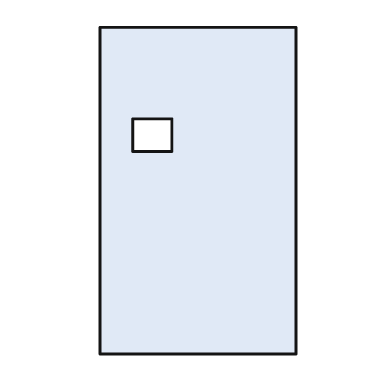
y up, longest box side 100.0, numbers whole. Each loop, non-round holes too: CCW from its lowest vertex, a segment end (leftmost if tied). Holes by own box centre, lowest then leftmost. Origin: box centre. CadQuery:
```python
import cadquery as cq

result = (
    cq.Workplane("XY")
    .moveTo(-30.0, -50.0)
    .lineTo(30.0, -50.0)
    .lineTo(30.0, 50.0)
    .lineTo(-30.0, 50.0)
    .close()
    .moveTo(-20.0, 12.0)
    .lineTo(-8.0, 12.0)
    .lineTo(-8.0, 22.0)
    .lineTo(-20.0, 22.0)
    .close()
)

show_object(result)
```